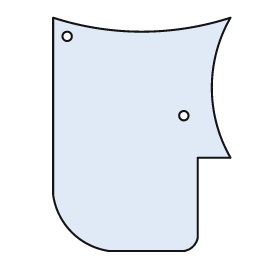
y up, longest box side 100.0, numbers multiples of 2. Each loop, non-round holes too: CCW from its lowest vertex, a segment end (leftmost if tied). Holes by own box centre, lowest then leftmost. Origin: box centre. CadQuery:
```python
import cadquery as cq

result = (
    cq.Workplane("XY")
    .moveTo(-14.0, -50.0)
    .lineTo(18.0, -50.0)
    .threePointArc((22.0, -48.0), (24.0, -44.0))
    .lineTo(24.0, -10.0)
    .lineTo(38.0, -10.0)
    .threePointArc((30.0, 20.0), (38.0, 50.0))
    .threePointArc((0.0, 44.0), (-38.0, 50.0))
    .lineTo(-38.0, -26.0)
    .threePointArc((-30.0, -42.0), (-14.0, -50.0))
    .close()
    .moveTo(18.0, 8.0)
    .circle(2.0)
    .moveTo(-32.0, 42.0)
    .circle(2.0)
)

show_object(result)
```